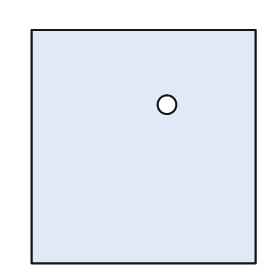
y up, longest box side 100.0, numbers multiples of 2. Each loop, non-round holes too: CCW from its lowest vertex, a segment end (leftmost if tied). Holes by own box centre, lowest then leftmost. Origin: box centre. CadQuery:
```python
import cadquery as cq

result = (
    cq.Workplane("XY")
    .moveTo(-48.0, -50.0)
    .lineTo(48.0, -50.0)
    .lineTo(48.0, 50.0)
    .lineTo(-48.0, 50.0)
    .close()
    .moveTo(10.0, 18.0)
    .circle(4.0)
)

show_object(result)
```